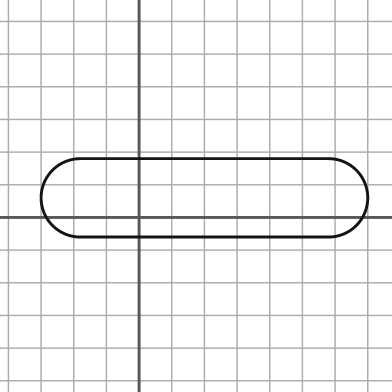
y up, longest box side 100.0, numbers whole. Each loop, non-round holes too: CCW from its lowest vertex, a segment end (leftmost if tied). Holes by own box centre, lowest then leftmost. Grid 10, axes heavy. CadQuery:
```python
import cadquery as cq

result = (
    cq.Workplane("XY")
    .moveTo(-18.0, -6.0)
    .lineTo(58.0, -6.0)
    .threePointArc((70.0, 6.0), (58.0, 18.0))
    .lineTo(-18.0, 18.0)
    .threePointArc((-30.0, 6.0), (-18.0, -6.0))
    .close()
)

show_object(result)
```